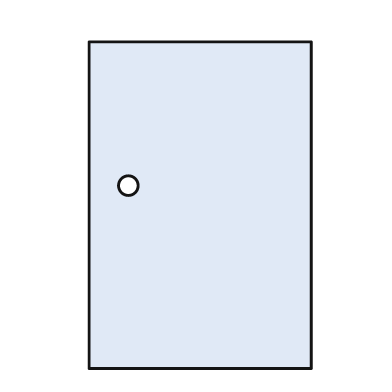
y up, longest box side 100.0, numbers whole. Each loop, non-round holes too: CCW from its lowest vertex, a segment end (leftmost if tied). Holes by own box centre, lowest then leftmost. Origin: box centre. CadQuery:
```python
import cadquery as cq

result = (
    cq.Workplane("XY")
    .moveTo(-34.0, -50.0)
    .lineTo(34.0, -50.0)
    .lineTo(34.0, 50.0)
    .lineTo(-34.0, 50.0)
    .close()
    .moveTo(-22.0, 6.0)
    .circle(3.0)
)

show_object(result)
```